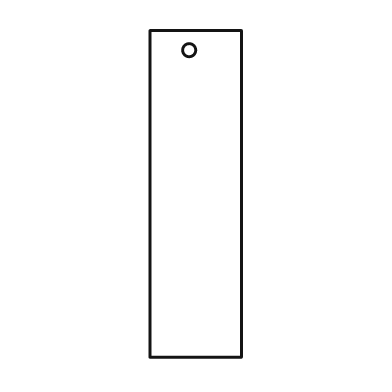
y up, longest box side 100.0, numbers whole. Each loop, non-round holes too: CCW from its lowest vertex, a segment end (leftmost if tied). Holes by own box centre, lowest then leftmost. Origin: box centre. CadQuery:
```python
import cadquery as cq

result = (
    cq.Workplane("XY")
    .moveTo(-14.0, -50.0)
    .lineTo(14.0, -50.0)
    .lineTo(14.0, 50.0)
    .lineTo(-14.0, 50.0)
    .close()
    .moveTo(-2.0, 44.0)
    .circle(2.0)
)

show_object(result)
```